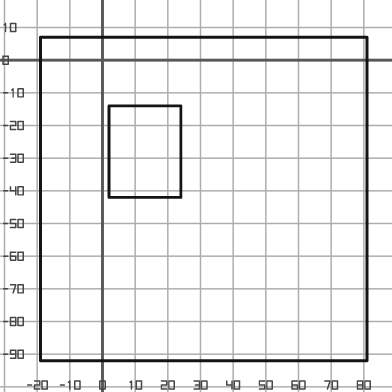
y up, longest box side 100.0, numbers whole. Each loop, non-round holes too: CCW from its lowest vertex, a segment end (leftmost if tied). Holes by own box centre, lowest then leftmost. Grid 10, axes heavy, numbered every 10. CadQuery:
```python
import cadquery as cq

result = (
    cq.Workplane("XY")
    .moveTo(-19.0, -92.0)
    .lineTo(81.0, -92.0)
    .lineTo(81.0, 7.0)
    .lineTo(-19.0, 7.0)
    .close()
    .moveTo(2.0, -42.0)
    .lineTo(24.0, -42.0)
    .lineTo(24.0, -14.0)
    .lineTo(2.0, -14.0)
    .close()
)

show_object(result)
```